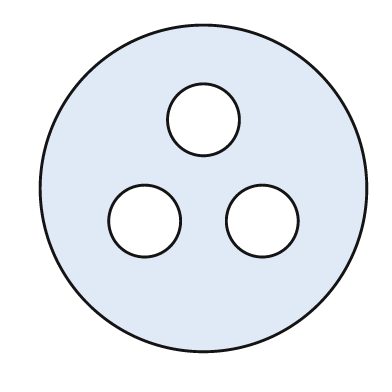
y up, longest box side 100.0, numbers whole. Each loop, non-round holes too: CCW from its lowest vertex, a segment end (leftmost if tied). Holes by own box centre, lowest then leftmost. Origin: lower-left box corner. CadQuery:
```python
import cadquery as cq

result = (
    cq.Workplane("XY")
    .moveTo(50.0, 50.0)
    .circle(50.0)
    .moveTo(32.0, 40.0)
    .circle(11.0)
    .moveTo(68.0, 40.0)
    .circle(11.0)
    .moveTo(50.0, 71.0)
    .circle(11.0)
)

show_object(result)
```